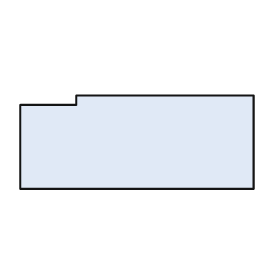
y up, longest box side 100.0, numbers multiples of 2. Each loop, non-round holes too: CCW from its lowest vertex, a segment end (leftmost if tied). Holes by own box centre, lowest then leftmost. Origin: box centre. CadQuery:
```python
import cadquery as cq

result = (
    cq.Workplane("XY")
    .moveTo(-50.0, -20.0)
    .lineTo(50.0, -20.0)
    .lineTo(50.0, 20.0)
    .lineTo(-26.0, 20.0)
    .lineTo(-26.0, 16.0)
    .lineTo(-50.0, 16.0)
    .close()
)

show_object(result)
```